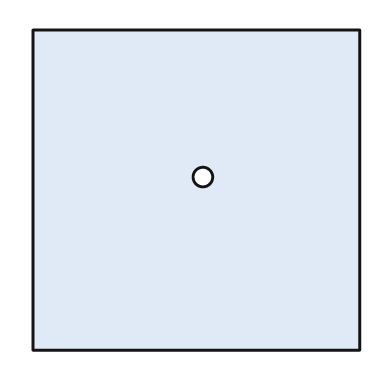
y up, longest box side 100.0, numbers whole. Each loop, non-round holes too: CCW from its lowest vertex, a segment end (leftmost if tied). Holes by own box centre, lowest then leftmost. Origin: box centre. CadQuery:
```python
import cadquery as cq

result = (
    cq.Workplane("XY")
    .moveTo(-50.0, -49.0)
    .lineTo(50.0, -49.0)
    .lineTo(50.0, 49.0)
    .lineTo(-50.0, 49.0)
    .close()
    .moveTo(2.0, 4.0)
    .circle(3.0)
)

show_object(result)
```